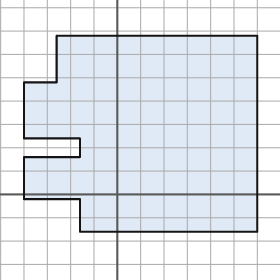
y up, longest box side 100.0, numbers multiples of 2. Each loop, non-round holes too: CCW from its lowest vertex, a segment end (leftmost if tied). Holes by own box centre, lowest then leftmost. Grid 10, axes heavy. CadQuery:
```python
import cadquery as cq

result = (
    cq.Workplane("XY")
    .moveTo(-16.0, -16.0)
    .lineTo(60.0, -16.0)
    .lineTo(60.0, 68.0)
    .lineTo(-26.0, 68.0)
    .lineTo(-26.0, 48.0)
    .lineTo(-40.0, 48.0)
    .lineTo(-40.0, 24.0)
    .lineTo(-16.0, 24.0)
    .lineTo(-16.0, 16.0)
    .lineTo(-40.0, 16.0)
    .lineTo(-40.0, -2.0)
    .lineTo(-16.0, -2.0)
    .close()
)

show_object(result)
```